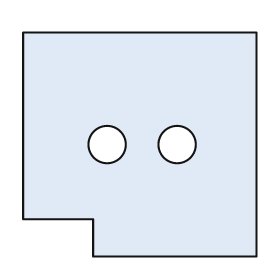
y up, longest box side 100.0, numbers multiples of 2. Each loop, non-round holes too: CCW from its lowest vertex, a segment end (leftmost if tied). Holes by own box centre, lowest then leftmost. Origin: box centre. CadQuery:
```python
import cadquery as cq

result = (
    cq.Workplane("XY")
    .moveTo(-20.0, -48.0)
    .lineTo(50.0, -48.0)
    .lineTo(50.0, 48.0)
    .lineTo(-50.0, 48.0)
    .lineTo(-50.0, -32.0)
    .lineTo(-20.0, -32.0)
    .close()
    .moveTo(-14.0, 0.0)
    .circle(8.0)
    .moveTo(16.0, 0.0)
    .circle(8.0)
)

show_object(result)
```